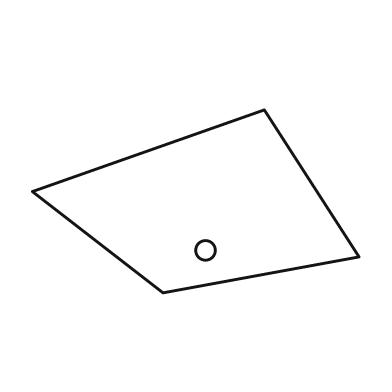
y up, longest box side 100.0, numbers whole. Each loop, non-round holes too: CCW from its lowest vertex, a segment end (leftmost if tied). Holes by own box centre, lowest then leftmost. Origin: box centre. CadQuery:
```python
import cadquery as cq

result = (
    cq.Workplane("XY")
    .moveTo(-10.0, -28.0)
    .lineTo(50.0, -17.0)
    .lineTo(21.0, 28.0)
    .lineTo(-50.0, 3.0)
    .close()
    .moveTo(3.0, -15.0)
    .circle(3.0)
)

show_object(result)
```